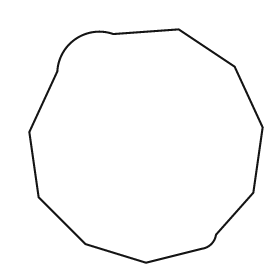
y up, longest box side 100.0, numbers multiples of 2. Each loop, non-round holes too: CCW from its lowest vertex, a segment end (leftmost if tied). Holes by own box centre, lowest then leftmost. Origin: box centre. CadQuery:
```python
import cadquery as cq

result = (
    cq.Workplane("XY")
    .moveTo(0.0, -50.0)
    .lineTo(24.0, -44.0)
    .threePointArc((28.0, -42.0), (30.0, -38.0))
    .lineTo(46.0, -20.0)
    .lineTo(50.0, 8.0)
    .lineTo(38.0, 34.0)
    .lineTo(14.0, 50.0)
    .lineTo(-14.0, 48.0)
    .threePointArc((-30.0, 46.0), (-38.0, 32.0))
    .lineTo(-50.0, 6.0)
    .lineTo(-46.0, -22.0)
    .lineTo(-26.0, -42.0)
    .close()
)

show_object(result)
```